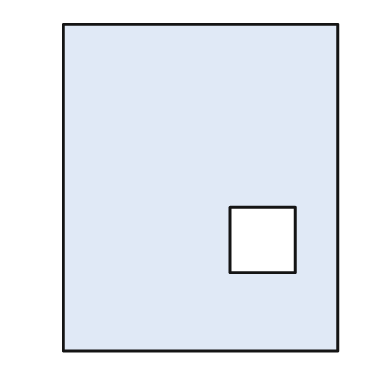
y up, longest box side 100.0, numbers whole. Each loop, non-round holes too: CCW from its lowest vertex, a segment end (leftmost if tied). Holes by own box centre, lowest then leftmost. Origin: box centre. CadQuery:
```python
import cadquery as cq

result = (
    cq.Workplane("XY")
    .moveTo(-42.0, -50.0)
    .lineTo(42.0, -50.0)
    .lineTo(42.0, 50.0)
    .lineTo(-42.0, 50.0)
    .close()
    .moveTo(9.0, -26.0)
    .lineTo(29.0, -26.0)
    .lineTo(29.0, -6.0)
    .lineTo(9.0, -6.0)
    .close()
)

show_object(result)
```